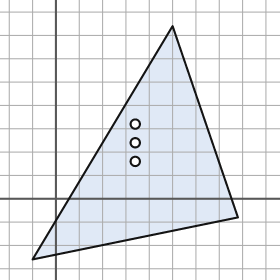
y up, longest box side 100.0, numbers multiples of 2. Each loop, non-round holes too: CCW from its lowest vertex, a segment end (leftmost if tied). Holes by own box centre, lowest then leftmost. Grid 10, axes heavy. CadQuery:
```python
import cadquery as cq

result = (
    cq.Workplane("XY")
    .moveTo(-10.0, -26.0)
    .lineTo(78.0, -8.0)
    .lineTo(50.0, 74.0)
    .close()
    .moveTo(34.0, 16.0)
    .circle(2.0)
    .moveTo(34.0, 24.0)
    .circle(2.0)
    .moveTo(34.0, 32.0)
    .circle(2.0)
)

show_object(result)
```